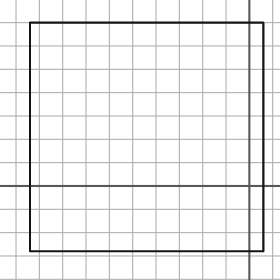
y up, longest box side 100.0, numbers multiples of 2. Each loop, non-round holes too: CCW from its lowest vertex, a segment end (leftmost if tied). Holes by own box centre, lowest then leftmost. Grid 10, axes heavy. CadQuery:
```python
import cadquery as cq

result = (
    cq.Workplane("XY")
    .moveTo(-94.0, -28.0)
    .lineTo(6.0, -28.0)
    .lineTo(6.0, 70.0)
    .lineTo(-94.0, 70.0)
    .close()
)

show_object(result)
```